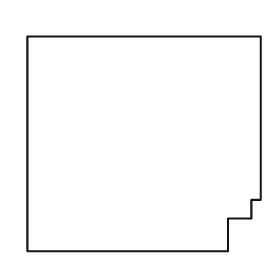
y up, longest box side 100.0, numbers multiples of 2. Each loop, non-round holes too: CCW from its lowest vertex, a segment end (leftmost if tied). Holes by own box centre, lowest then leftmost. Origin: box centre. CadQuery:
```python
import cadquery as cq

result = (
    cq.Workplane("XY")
    .moveTo(-50.0, -46.0)
    .lineTo(36.0, -46.0)
    .lineTo(36.0, -32.0)
    .lineTo(46.0, -32.0)
    .lineTo(46.0, -24.0)
    .lineTo(50.0, -24.0)
    .lineTo(50.0, 46.0)
    .lineTo(-50.0, 46.0)
    .close()
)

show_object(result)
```